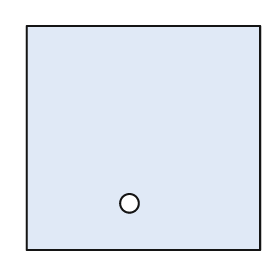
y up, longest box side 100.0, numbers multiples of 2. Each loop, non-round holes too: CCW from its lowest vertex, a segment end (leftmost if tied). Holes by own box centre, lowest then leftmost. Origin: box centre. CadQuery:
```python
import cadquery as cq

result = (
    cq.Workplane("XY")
    .moveTo(-50.0, -48.0)
    .lineTo(50.0, -48.0)
    .lineTo(50.0, 48.0)
    .lineTo(-50.0, 48.0)
    .close()
    .moveTo(-6.0, -28.0)
    .circle(4.0)
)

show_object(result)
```